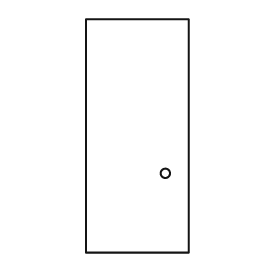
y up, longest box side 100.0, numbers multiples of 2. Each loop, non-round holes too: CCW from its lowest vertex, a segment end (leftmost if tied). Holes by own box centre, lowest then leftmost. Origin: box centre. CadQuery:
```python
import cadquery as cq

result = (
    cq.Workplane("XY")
    .moveTo(-22.0, -50.0)
    .lineTo(22.0, -50.0)
    .lineTo(22.0, 50.0)
    .lineTo(-22.0, 50.0)
    .close()
    .moveTo(12.0, -16.0)
    .circle(2.0)
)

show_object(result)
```